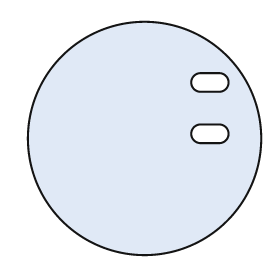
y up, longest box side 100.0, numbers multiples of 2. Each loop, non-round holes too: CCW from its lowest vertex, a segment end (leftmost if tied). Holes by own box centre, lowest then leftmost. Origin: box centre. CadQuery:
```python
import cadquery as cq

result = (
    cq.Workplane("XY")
    .moveTo(0.0, 0.0)
    .circle(50.0)
    .moveTo(24.0, -2.0)
    .lineTo(32.0, -2.0)
    .threePointArc((36.0, 2.0), (32.0, 6.0))
    .lineTo(24.0, 6.0)
    .threePointArc((20.0, 2.0), (24.0, -2.0))
    .close()
    .moveTo(24.0, 20.0)
    .lineTo(32.0, 20.0)
    .threePointArc((36.0, 24.0), (32.0, 28.0))
    .lineTo(24.0, 28.0)
    .threePointArc((20.0, 24.0), (24.0, 20.0))
    .close()
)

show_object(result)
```